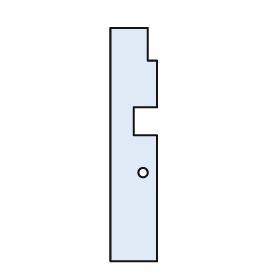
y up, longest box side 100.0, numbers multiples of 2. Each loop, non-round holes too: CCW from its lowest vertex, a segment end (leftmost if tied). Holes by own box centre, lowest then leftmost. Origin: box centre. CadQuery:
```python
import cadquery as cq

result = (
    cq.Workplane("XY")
    .moveTo(-10.0, -50.0)
    .lineTo(10.0, -50.0)
    .lineTo(10.0, 4.0)
    .lineTo(0.0, 4.0)
    .lineTo(0.0, 16.0)
    .lineTo(10.0, 16.0)
    .lineTo(10.0, 36.0)
    .lineTo(6.0, 36.0)
    .lineTo(6.0, 50.0)
    .lineTo(-10.0, 50.0)
    .close()
    .moveTo(4.0, -12.0)
    .circle(2.0)
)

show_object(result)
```